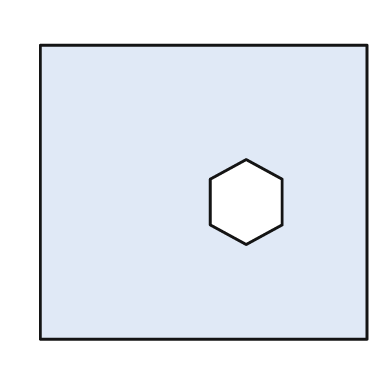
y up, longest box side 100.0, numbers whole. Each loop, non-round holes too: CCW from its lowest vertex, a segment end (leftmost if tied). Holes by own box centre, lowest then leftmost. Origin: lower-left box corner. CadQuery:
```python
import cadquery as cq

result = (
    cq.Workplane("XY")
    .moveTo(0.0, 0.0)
    .lineTo(100.0, 0.0)
    .lineTo(100.0, 90.0)
    .lineTo(0.0, 90.0)
    .close()
    .moveTo(63.0, 29.0)
    .lineTo(74.0, 35.0)
    .lineTo(74.0, 49.0)
    .lineTo(63.0, 55.0)
    .lineTo(52.0, 49.0)
    .lineTo(52.0, 35.0)
    .close()
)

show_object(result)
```